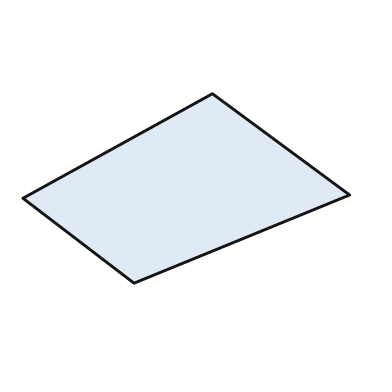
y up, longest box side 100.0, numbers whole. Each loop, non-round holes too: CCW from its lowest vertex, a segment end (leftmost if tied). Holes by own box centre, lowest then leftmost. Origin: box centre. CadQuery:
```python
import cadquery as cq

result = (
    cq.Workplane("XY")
    .moveTo(-16.0, -29.0)
    .lineTo(50.0, -2.0)
    .lineTo(8.0, 29.0)
    .lineTo(-50.0, -3.0)
    .close()
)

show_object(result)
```